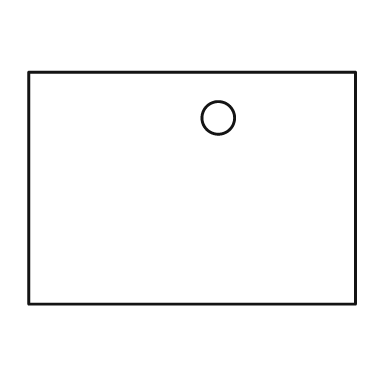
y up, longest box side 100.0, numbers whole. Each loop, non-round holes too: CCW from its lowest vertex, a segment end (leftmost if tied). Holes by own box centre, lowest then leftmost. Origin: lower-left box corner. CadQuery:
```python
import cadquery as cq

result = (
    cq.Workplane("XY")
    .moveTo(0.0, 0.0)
    .lineTo(100.0, 0.0)
    .lineTo(100.0, 71.0)
    .lineTo(0.0, 71.0)
    .close()
    .moveTo(58.0, 57.0)
    .circle(5.0)
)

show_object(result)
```